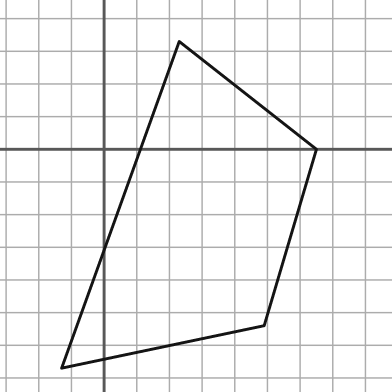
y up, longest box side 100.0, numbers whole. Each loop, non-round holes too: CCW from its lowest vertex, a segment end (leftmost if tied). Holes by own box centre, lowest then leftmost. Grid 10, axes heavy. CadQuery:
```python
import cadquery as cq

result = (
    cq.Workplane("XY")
    .moveTo(-13.0, -67.0)
    .lineTo(49.0, -54.0)
    .lineTo(65.0, 0.0)
    .lineTo(23.0, 33.0)
    .close()
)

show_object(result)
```